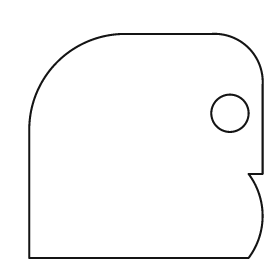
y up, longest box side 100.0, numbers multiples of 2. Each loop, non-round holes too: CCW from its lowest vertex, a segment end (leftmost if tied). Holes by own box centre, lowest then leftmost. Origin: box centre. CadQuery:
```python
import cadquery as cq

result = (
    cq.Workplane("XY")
    .moveTo(-50.0, -48.0)
    .lineTo(44.0, -48.0)
    .threePointArc((50.0, -30.0), (44.0, -12.0))
    .lineTo(50.0, -12.0)
    .lineTo(50.0, 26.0)
    .threePointArc((44.0, 42.0), (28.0, 48.0))
    .lineTo(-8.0, 48.0)
    .threePointArc((-38.0, 36.0), (-50.0, 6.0))
    .close()
    .moveTo(36.0, 14.0)
    .circle(8.0)
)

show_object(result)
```